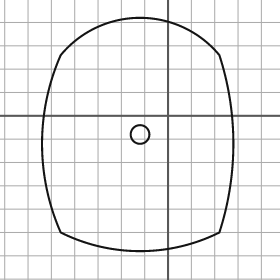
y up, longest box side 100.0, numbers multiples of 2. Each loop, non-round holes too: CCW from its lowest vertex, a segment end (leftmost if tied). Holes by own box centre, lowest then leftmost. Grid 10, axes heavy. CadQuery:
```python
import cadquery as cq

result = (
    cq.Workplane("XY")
    .moveTo(-46.0, -50.0)
    .threePointArc((-12.0, -58.0), (22.0, -50.0))
    .threePointArc((28.0, -12.0), (22.0, 26.0))
    .threePointArc((-12.0, 42.0), (-46.0, 26.0))
    .threePointArc((-54.0, -12.0), (-46.0, -50.0))
    .close()
    .moveTo(-12.0, -8.0)
    .circle(4.0)
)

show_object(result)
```